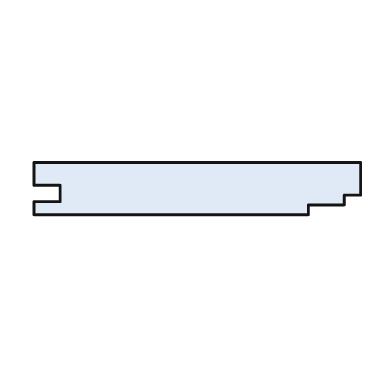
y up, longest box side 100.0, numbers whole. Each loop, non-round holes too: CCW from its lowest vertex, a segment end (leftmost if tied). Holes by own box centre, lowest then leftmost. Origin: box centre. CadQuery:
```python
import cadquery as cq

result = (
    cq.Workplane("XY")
    .moveTo(-50.0, -8.0)
    .lineTo(34.0, -8.0)
    .lineTo(34.0, -5.0)
    .lineTo(45.0, -5.0)
    .lineTo(45.0, -2.0)
    .lineTo(50.0, -2.0)
    .lineTo(50.0, 8.0)
    .lineTo(-50.0, 8.0)
    .lineTo(-50.0, 1.0)
    .lineTo(-42.0, 1.0)
    .lineTo(-42.0, -4.0)
    .lineTo(-50.0, -4.0)
    .close()
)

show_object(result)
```